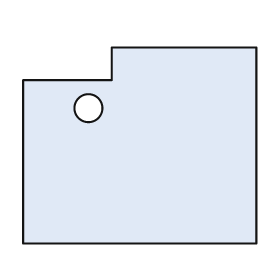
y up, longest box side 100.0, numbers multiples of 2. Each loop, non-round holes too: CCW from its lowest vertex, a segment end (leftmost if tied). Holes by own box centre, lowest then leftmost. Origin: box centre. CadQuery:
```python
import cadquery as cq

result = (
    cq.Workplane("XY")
    .moveTo(-50.0, -42.0)
    .lineTo(50.0, -42.0)
    .lineTo(50.0, 42.0)
    .lineTo(-12.0, 42.0)
    .lineTo(-12.0, 28.0)
    .lineTo(-50.0, 28.0)
    .close()
    .moveTo(-22.0, 16.0)
    .circle(6.0)
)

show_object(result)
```